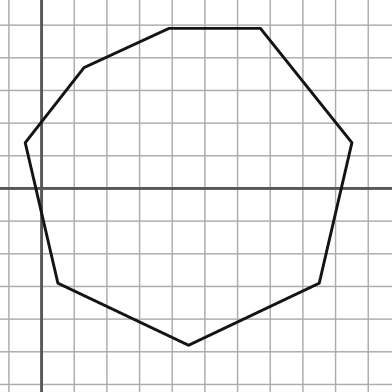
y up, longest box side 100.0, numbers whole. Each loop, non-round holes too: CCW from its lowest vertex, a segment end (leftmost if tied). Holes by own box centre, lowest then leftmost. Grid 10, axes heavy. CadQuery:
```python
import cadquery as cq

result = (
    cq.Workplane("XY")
    .moveTo(45.0, -48.0)
    .lineTo(85.0, -29.0)
    .lineTo(95.0, 14.0)
    .lineTo(67.0, 49.0)
    .lineTo(39.0, 49.0)
    .lineTo(13.0, 37.0)
    .lineTo(-5.0, 14.0)
    .lineTo(5.0, -29.0)
    .close()
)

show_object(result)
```